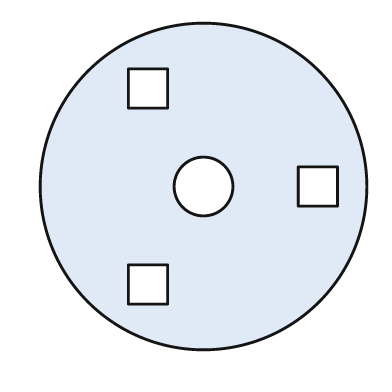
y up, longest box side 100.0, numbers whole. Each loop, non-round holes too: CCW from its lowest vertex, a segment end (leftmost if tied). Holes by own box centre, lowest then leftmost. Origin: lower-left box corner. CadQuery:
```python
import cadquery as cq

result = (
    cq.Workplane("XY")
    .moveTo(50.0, 50.0)
    .circle(50.0)
    .moveTo(27.0, 14.0)
    .lineTo(39.0, 14.0)
    .lineTo(39.0, 26.0)
    .lineTo(27.0, 26.0)
    .close()
    .moveTo(50.0, 50.0)
    .circle(9.0)
    .moveTo(79.0, 44.0)
    .lineTo(91.0, 44.0)
    .lineTo(91.0, 56.0)
    .lineTo(79.0, 56.0)
    .close()
    .moveTo(27.0, 74.0)
    .lineTo(39.0, 74.0)
    .lineTo(39.0, 86.0)
    .lineTo(27.0, 86.0)
    .close()
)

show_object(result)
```